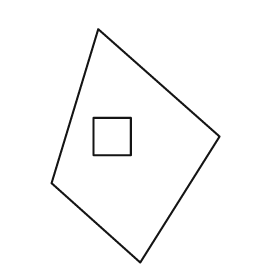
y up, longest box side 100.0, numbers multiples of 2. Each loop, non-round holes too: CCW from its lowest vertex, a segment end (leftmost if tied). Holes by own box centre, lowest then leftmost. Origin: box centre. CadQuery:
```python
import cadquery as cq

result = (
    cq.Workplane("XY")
    .moveTo(2.0, -50.0)
    .lineTo(36.0, 4.0)
    .lineTo(-16.0, 50.0)
    .lineTo(-36.0, -16.0)
    .close()
    .moveTo(-18.0, -4.0)
    .lineTo(-2.0, -4.0)
    .lineTo(-2.0, 12.0)
    .lineTo(-18.0, 12.0)
    .close()
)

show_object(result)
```